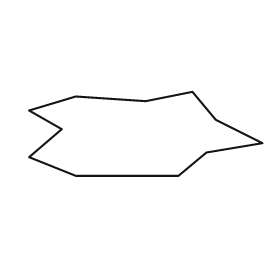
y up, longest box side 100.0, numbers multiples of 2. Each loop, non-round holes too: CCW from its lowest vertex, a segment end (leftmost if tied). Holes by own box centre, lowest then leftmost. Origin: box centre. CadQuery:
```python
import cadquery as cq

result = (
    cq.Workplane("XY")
    .moveTo(-30.0, -18.0)
    .lineTo(14.0, -18.0)
    .lineTo(26.0, -8.0)
    .lineTo(50.0, -4.0)
    .lineTo(30.0, 6.0)
    .lineTo(20.0, 18.0)
    .lineTo(0.0, 14.0)
    .lineTo(-30.0, 16.0)
    .lineTo(-50.0, 10.0)
    .lineTo(-36.0, 2.0)
    .lineTo(-50.0, -10.0)
    .close()
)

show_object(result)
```